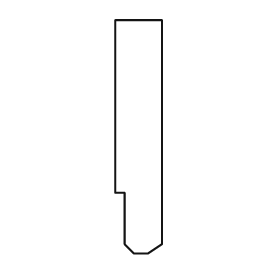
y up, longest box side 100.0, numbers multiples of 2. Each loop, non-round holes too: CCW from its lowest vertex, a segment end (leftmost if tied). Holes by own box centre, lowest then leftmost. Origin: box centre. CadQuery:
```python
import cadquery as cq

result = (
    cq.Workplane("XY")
    .moveTo(-2.0, -50.0)
    .lineTo(4.0, -50.0)
    .lineTo(10.0, -46.0)
    .lineTo(10.0, 50.0)
    .lineTo(-10.0, 50.0)
    .lineTo(-10.0, -24.0)
    .lineTo(-6.0, -24.0)
    .lineTo(-6.0, -46.0)
    .close()
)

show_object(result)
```